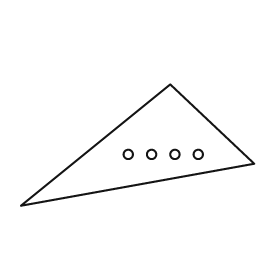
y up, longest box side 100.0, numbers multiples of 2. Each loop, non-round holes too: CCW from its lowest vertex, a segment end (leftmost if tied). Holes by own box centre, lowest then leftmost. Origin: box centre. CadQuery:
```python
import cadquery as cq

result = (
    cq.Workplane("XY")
    .moveTo(-50.0, -26.0)
    .lineTo(50.0, -8.0)
    .lineTo(14.0, 26.0)
    .close()
    .moveTo(-4.0, -4.0)
    .circle(2.0)
    .moveTo(6.0, -4.0)
    .circle(2.0)
    .moveTo(16.0, -4.0)
    .circle(2.0)
    .moveTo(26.0, -4.0)
    .circle(2.0)
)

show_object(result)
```